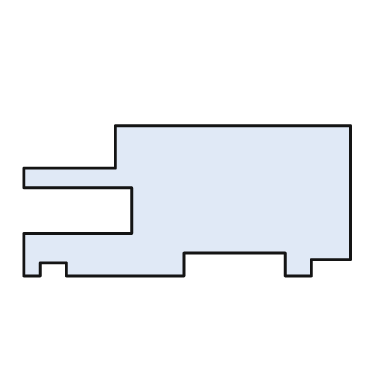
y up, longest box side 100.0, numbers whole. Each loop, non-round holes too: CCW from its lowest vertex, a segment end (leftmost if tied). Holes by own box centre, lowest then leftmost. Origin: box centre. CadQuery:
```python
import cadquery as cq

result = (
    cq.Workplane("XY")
    .moveTo(-50.0, -23.0)
    .lineTo(-45.0, -23.0)
    .lineTo(-45.0, -19.0)
    .lineTo(-37.0, -19.0)
    .lineTo(-37.0, -23.0)
    .lineTo(-1.0, -23.0)
    .lineTo(-1.0, -16.0)
    .lineTo(30.0, -16.0)
    .lineTo(30.0, -23.0)
    .lineTo(38.0, -23.0)
    .lineTo(38.0, -18.0)
    .lineTo(50.0, -18.0)
    .lineTo(50.0, 23.0)
    .lineTo(-22.0, 23.0)
    .lineTo(-22.0, 10.0)
    .lineTo(-50.0, 10.0)
    .lineTo(-50.0, 4.0)
    .lineTo(-17.0, 4.0)
    .lineTo(-17.0, -10.0)
    .lineTo(-50.0, -10.0)
    .close()
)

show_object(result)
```